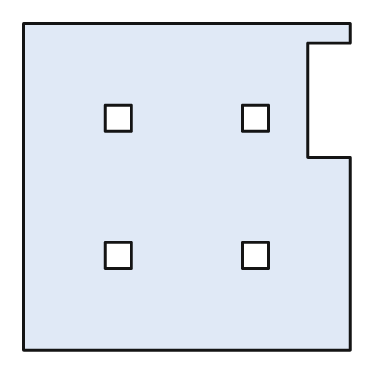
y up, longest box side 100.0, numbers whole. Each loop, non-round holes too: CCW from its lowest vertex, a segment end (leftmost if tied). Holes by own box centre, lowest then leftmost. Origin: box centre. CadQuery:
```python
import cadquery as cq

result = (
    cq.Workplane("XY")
    .moveTo(-50.0, -50.0)
    .lineTo(50.0, -50.0)
    .lineTo(50.0, 9.0)
    .lineTo(37.0, 9.0)
    .lineTo(37.0, 44.0)
    .lineTo(50.0, 44.0)
    .lineTo(50.0, 50.0)
    .lineTo(-50.0, 50.0)
    .close()
    .moveTo(-25.0, -25.0)
    .lineTo(-17.0, -25.0)
    .lineTo(-17.0, -17.0)
    .lineTo(-25.0, -17.0)
    .close()
    .moveTo(17.0, -25.0)
    .lineTo(25.0, -25.0)
    .lineTo(25.0, -17.0)
    .lineTo(17.0, -17.0)
    .close()
    .moveTo(-25.0, 17.0)
    .lineTo(-17.0, 17.0)
    .lineTo(-17.0, 25.0)
    .lineTo(-25.0, 25.0)
    .close()
    .moveTo(17.0, 17.0)
    .lineTo(25.0, 17.0)
    .lineTo(25.0, 25.0)
    .lineTo(17.0, 25.0)
    .close()
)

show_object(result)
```